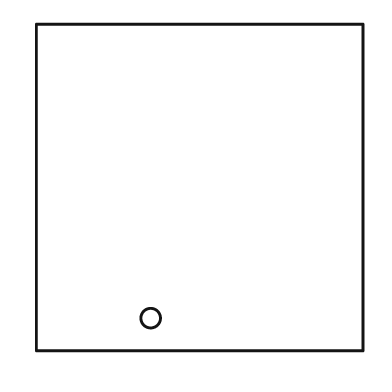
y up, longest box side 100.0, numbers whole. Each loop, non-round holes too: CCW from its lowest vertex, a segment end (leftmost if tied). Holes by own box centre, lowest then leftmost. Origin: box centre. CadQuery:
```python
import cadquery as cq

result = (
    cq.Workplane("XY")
    .moveTo(-50.0, -50.0)
    .lineTo(50.0, -50.0)
    .lineTo(50.0, 50.0)
    .lineTo(-50.0, 50.0)
    .close()
    .moveTo(-15.0, -40.0)
    .circle(3.0)
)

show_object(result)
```